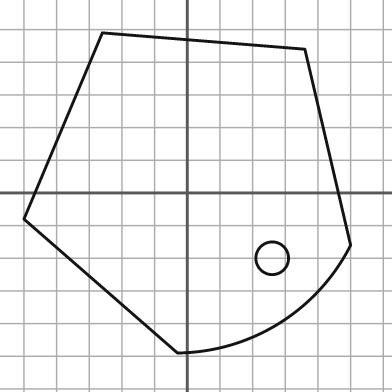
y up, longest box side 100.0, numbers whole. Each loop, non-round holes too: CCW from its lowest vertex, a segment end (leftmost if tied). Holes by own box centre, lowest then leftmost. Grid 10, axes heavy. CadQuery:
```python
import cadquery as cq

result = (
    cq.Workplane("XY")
    .moveTo(-3.0, -49.0)
    .threePointArc((28.0, -40.0), (50.0, -16.0))
    .lineTo(36.0, 44.0)
    .lineTo(-26.0, 49.0)
    .lineTo(-50.0, -8.0)
    .close()
    .moveTo(26.0, -20.0)
    .circle(5.0)
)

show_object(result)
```